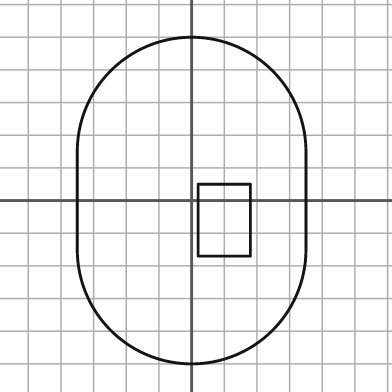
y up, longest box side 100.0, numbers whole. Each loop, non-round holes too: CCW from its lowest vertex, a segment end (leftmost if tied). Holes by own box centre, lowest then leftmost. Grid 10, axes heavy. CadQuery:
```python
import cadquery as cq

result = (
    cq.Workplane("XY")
    .moveTo(-35.0, -15.0)
    .threePointArc((0.0, -50.0), (35.0, -15.0))
    .lineTo(35.0, 15.0)
    .threePointArc((0.0, 50.0), (-35.0, 15.0))
    .close()
    .moveTo(2.0, -17.0)
    .lineTo(18.0, -17.0)
    .lineTo(18.0, 5.0)
    .lineTo(2.0, 5.0)
    .close()
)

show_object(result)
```